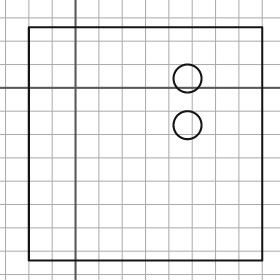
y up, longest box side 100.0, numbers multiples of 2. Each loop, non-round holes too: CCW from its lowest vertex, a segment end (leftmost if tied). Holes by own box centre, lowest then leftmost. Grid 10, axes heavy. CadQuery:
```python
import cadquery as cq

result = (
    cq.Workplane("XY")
    .moveTo(-20.0, -74.0)
    .lineTo(80.0, -74.0)
    .lineTo(80.0, 26.0)
    .lineTo(-20.0, 26.0)
    .close()
    .moveTo(48.0, -16.0)
    .circle(6.0)
    .moveTo(48.0, 4.0)
    .circle(6.0)
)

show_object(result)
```